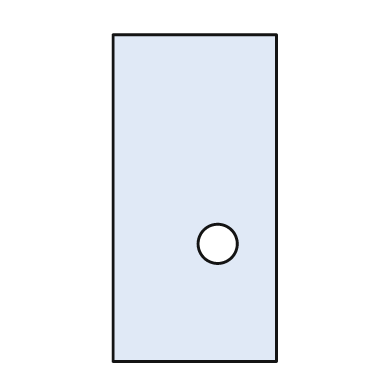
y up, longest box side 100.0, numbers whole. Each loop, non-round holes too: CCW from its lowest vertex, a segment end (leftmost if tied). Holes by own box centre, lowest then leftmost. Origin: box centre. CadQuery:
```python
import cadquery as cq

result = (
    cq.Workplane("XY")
    .moveTo(-25.0, -50.0)
    .lineTo(25.0, -50.0)
    .lineTo(25.0, 50.0)
    .lineTo(-25.0, 50.0)
    .close()
    .moveTo(7.0, -14.0)
    .circle(6.0)
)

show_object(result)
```